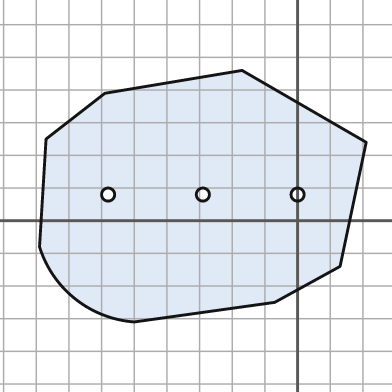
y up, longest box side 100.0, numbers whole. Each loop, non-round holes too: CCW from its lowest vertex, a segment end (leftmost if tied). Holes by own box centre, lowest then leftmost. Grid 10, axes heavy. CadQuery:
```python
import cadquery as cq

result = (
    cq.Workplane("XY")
    .moveTo(-50.0, -31.0)
    .lineTo(-7.0, -25.0)
    .lineTo(13.0, -14.0)
    .lineTo(21.0, 24.0)
    .lineTo(-17.0, 46.0)
    .lineTo(-59.0, 39.0)
    .lineTo(-77.0, 25.0)
    .lineTo(-79.0, -8.0)
    .threePointArc((-68.0, -24.0), (-50.0, -31.0))
    .close()
    .moveTo(-58.0, 8.0)
    .circle(2.0)
    .moveTo(-29.0, 8.0)
    .circle(2.0)
    .moveTo(0.0, 8.0)
    .circle(2.0)
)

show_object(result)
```